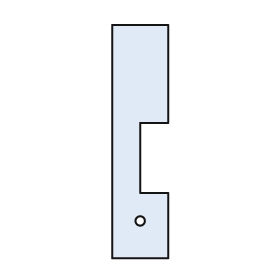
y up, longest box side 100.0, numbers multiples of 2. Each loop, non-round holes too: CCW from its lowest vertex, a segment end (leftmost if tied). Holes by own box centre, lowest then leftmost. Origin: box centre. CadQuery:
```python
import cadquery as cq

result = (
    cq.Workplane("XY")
    .moveTo(-12.0, -50.0)
    .lineTo(12.0, -50.0)
    .lineTo(12.0, -22.0)
    .lineTo(0.0, -22.0)
    .lineTo(0.0, 8.0)
    .lineTo(12.0, 8.0)
    .lineTo(12.0, 50.0)
    .lineTo(-12.0, 50.0)
    .close()
    .moveTo(0.0, -34.0)
    .circle(2.0)
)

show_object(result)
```